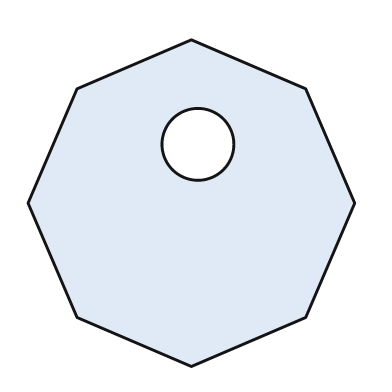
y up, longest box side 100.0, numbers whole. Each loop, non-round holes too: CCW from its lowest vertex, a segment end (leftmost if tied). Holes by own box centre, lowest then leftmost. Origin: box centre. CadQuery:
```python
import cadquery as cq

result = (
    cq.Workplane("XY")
    .moveTo(0.0, -50.0)
    .lineTo(35.0, -35.0)
    .lineTo(50.0, 0.0)
    .lineTo(35.0, 35.0)
    .lineTo(0.0, 50.0)
    .lineTo(-35.0, 35.0)
    .lineTo(-50.0, 0.0)
    .lineTo(-35.0, -35.0)
    .close()
    .moveTo(2.0, 18.0)
    .circle(11.0)
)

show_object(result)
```